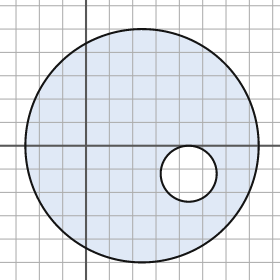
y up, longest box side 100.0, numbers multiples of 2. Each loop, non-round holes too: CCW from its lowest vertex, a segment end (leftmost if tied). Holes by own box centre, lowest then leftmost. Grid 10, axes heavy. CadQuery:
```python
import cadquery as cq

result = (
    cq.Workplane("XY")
    .moveTo(24.0, 0.0)
    .circle(50.0)
    .moveTo(44.0, -12.0)
    .circle(12.0)
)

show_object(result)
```